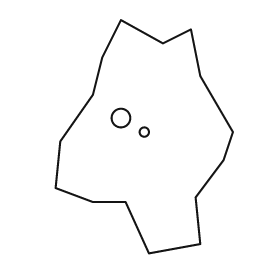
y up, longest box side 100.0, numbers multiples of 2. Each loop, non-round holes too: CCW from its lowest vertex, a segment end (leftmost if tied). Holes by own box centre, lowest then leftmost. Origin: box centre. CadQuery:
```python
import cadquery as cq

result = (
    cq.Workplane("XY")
    .moveTo(2.0, -50.0)
    .lineTo(24.0, -46.0)
    .lineTo(22.0, -26.0)
    .lineTo(34.0, -10.0)
    .lineTo(38.0, 2.0)
    .lineTo(24.0, 26.0)
    .lineTo(20.0, 46.0)
    .lineTo(8.0, 40.0)
    .lineTo(-10.0, 50.0)
    .lineTo(-18.0, 34.0)
    .lineTo(-22.0, 18.0)
    .lineTo(-36.0, -2.0)
    .lineTo(-38.0, -22.0)
    .lineTo(-22.0, -28.0)
    .lineTo(-8.0, -28.0)
    .close()
    .moveTo(0.0, 2.0)
    .circle(2.0)
    .moveTo(-10.0, 8.0)
    .circle(4.0)
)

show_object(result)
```